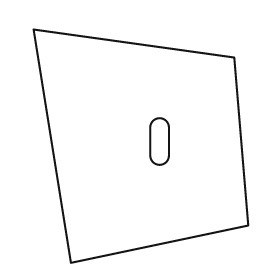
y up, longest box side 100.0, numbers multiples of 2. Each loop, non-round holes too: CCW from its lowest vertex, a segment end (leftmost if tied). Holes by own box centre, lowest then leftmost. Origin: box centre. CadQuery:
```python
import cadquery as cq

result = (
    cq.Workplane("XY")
    .moveTo(-30.0, -50.0)
    .lineTo(46.0, -34.0)
    .lineTo(40.0, 38.0)
    .lineTo(-46.0, 50.0)
    .close()
    .moveTo(4.0, -4.0)
    .threePointArc((8.0, -8.0), (12.0, -4.0))
    .lineTo(12.0, 8.0)
    .threePointArc((8.0, 12.0), (4.0, 8.0))
    .close()
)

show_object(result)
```